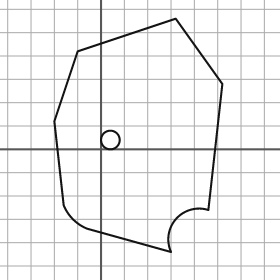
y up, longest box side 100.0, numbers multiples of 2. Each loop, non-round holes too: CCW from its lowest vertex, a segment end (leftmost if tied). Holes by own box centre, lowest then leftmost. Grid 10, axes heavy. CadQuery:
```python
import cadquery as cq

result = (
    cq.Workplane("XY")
    .moveTo(30.0, -44.0)
    .threePointArc((32.0, -30.0), (46.0, -26.0))
    .lineTo(52.0, 28.0)
    .lineTo(32.0, 56.0)
    .lineTo(-10.0, 42.0)
    .lineTo(-20.0, 12.0)
    .lineTo(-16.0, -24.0)
    .threePointArc((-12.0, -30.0), (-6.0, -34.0))
    .close()
    .moveTo(4.0, 4.0)
    .circle(4.0)
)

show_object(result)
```